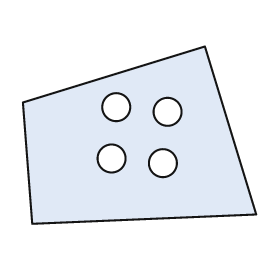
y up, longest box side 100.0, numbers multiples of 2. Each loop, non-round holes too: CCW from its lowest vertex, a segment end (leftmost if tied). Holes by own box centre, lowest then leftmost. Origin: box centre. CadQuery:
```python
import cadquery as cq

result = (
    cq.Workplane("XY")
    .moveTo(-46.0, -38.0)
    .lineTo(50.0, -34.0)
    .lineTo(28.0, 38.0)
    .lineTo(-50.0, 14.0)
    .close()
    .moveTo(10.0, -12.0)
    .circle(6.0)
    .moveTo(-12.0, -10.0)
    .circle(6.0)
    .moveTo(12.0, 10.0)
    .circle(6.0)
    .moveTo(-10.0, 12.0)
    .circle(6.0)
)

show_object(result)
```